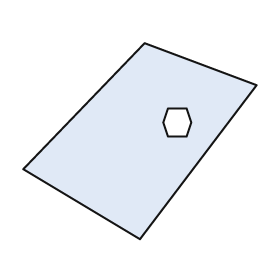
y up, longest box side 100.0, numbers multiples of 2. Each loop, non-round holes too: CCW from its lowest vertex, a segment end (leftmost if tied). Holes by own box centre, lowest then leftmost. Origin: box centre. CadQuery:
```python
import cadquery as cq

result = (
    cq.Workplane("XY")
    .moveTo(0.0, -42.0)
    .lineTo(50.0, 24.0)
    .lineTo(2.0, 42.0)
    .lineTo(-50.0, -12.0)
    .close()
    .moveTo(12.0, 2.0)
    .lineTo(20.0, 2.0)
    .lineTo(22.0, 8.0)
    .lineTo(20.0, 14.0)
    .lineTo(12.0, 14.0)
    .lineTo(10.0, 8.0)
    .close()
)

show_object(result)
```